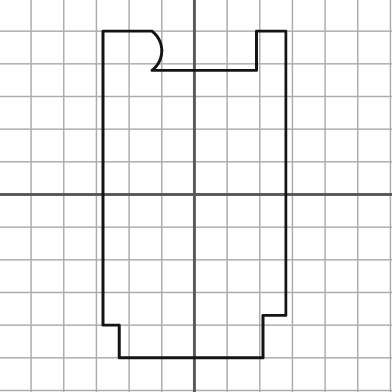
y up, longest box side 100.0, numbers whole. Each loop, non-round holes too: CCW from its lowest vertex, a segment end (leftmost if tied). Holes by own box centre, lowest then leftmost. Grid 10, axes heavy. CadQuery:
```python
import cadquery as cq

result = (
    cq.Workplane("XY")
    .moveTo(-23.0, -50.0)
    .lineTo(21.0, -50.0)
    .lineTo(21.0, -37.0)
    .lineTo(28.0, -37.0)
    .lineTo(28.0, 50.0)
    .lineTo(19.0, 50.0)
    .lineTo(19.0, 38.0)
    .lineTo(-13.0, 38.0)
    .threePointArc((-10.0, 44.0), (-13.0, 50.0))
    .lineTo(-28.0, 50.0)
    .lineTo(-28.0, -40.0)
    .lineTo(-23.0, -40.0)
    .close()
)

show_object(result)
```